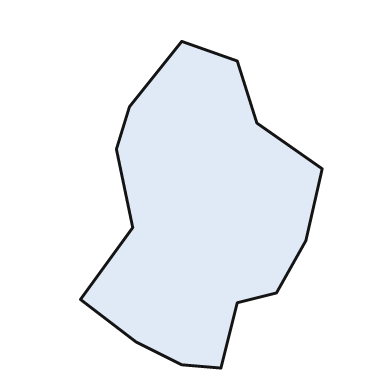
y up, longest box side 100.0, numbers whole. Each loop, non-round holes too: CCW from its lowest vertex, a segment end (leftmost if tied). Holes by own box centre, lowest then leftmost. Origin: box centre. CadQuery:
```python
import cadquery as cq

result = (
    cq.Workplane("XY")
    .moveTo(6.0, -50.0)
    .lineTo(11.0, -30.0)
    .lineTo(23.0, -27.0)
    .lineTo(32.0, -11.0)
    .lineTo(37.0, 11.0)
    .lineTo(17.0, 25.0)
    .lineTo(11.0, 44.0)
    .lineTo(-6.0, 50.0)
    .lineTo(-22.0, 30.0)
    .lineTo(-26.0, 17.0)
    .lineTo(-21.0, -7.0)
    .lineTo(-37.0, -29.0)
    .lineTo(-20.0, -42.0)
    .lineTo(-6.0, -49.0)
    .close()
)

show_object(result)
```